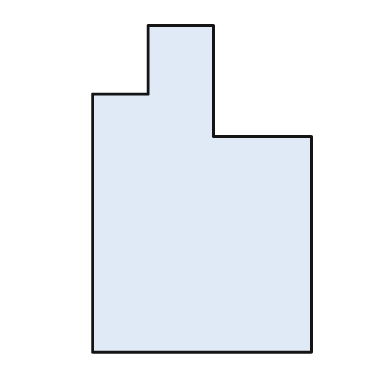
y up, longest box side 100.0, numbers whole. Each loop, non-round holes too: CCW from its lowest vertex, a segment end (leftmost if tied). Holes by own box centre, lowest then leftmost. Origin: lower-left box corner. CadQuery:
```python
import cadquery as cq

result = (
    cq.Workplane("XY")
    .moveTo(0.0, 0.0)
    .lineTo(67.0, 0.0)
    .lineTo(67.0, 66.0)
    .lineTo(37.0, 66.0)
    .lineTo(37.0, 100.0)
    .lineTo(17.0, 100.0)
    .lineTo(17.0, 79.0)
    .lineTo(0.0, 79.0)
    .close()
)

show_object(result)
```